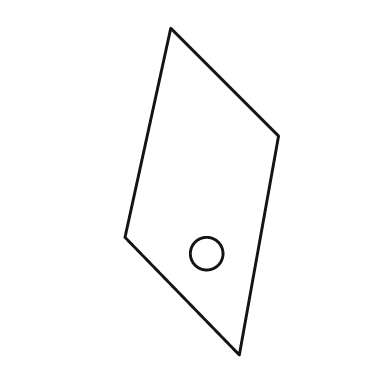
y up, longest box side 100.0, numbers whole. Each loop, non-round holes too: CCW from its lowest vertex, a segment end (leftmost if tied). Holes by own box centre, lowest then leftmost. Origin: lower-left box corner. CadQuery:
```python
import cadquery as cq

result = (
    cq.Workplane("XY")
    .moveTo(35.0, 0.0)
    .lineTo(47.0, 67.0)
    .lineTo(14.0, 100.0)
    .lineTo(0.0, 36.0)
    .close()
    .moveTo(25.0, 31.0)
    .circle(5.0)
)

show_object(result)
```